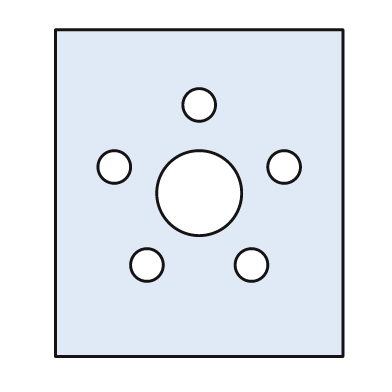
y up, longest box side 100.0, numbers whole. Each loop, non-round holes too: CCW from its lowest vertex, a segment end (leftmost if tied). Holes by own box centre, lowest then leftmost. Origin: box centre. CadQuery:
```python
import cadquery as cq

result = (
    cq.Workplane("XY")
    .moveTo(-44.0, -50.0)
    .lineTo(44.0, -50.0)
    .lineTo(44.0, 50.0)
    .lineTo(-44.0, 50.0)
    .close()
    .moveTo(-16.0, -22.0)
    .circle(5.0)
    .moveTo(16.0, -22.0)
    .circle(5.0)
    .moveTo(0.0, 0.0)
    .circle(13.0)
    .moveTo(-26.0, 8.0)
    .circle(5.0)
    .moveTo(26.0, 8.0)
    .circle(5.0)
    .moveTo(0.0, 27.0)
    .circle(5.0)
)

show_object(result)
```